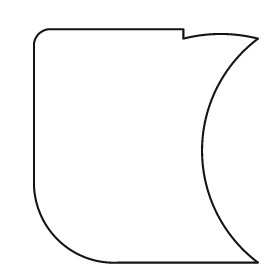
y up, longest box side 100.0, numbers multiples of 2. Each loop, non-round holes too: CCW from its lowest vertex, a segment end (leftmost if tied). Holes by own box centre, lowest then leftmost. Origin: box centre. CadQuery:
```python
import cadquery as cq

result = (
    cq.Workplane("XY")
    .moveTo(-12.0, -50.0)
    .lineTo(48.0, -50.0)
    .threePointArc((24.0, -2.0), (48.0, 46.0))
    .threePointArc((32.0, 48.0), (16.0, 46.0))
    .lineTo(16.0, 50.0)
    .lineTo(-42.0, 50.0)
    .threePointArc((-46.0, 48.0), (-48.0, 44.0))
    .lineTo(-48.0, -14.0)
    .threePointArc((-38.0, -40.0), (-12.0, -50.0))
    .close()
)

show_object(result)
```